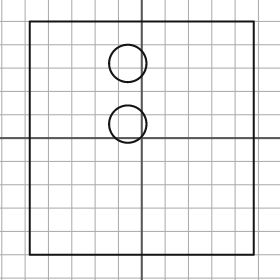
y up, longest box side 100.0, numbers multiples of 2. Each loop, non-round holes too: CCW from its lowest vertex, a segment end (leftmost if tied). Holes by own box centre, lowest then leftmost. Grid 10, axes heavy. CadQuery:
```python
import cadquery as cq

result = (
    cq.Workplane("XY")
    .moveTo(-48.0, -50.0)
    .lineTo(48.0, -50.0)
    .lineTo(48.0, 50.0)
    .lineTo(-48.0, 50.0)
    .close()
    .moveTo(-6.0, 6.0)
    .circle(8.0)
    .moveTo(-6.0, 32.0)
    .circle(8.0)
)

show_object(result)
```